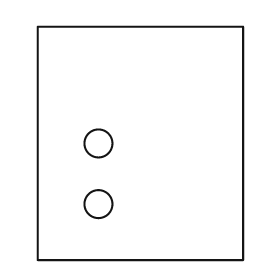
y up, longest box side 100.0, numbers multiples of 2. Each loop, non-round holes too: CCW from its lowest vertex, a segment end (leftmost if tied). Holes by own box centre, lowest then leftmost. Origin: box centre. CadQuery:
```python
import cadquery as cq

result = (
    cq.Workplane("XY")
    .moveTo(-44.0, -50.0)
    .lineTo(44.0, -50.0)
    .lineTo(44.0, 50.0)
    .lineTo(-44.0, 50.0)
    .close()
    .moveTo(-18.0, -26.0)
    .circle(6.0)
    .moveTo(-18.0, 0.0)
    .circle(6.0)
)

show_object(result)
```